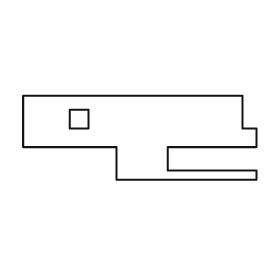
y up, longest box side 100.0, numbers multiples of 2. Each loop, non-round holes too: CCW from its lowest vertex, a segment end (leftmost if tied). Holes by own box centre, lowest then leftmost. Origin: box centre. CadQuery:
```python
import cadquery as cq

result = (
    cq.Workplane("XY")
    .moveTo(-10.0, -18.0)
    .lineTo(50.0, -18.0)
    .lineTo(50.0, -14.0)
    .lineTo(12.0, -14.0)
    .lineTo(12.0, -4.0)
    .lineTo(50.0, -4.0)
    .lineTo(50.0, 4.0)
    .lineTo(44.0, 4.0)
    .lineTo(44.0, 18.0)
    .lineTo(-50.0, 18.0)
    .lineTo(-50.0, -4.0)
    .lineTo(-10.0, -4.0)
    .close()
    .moveTo(-30.0, 4.0)
    .lineTo(-22.0, 4.0)
    .lineTo(-22.0, 12.0)
    .lineTo(-30.0, 12.0)
    .close()
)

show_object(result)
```